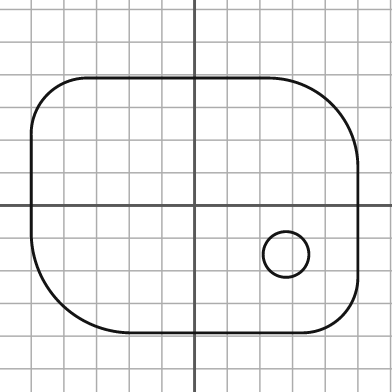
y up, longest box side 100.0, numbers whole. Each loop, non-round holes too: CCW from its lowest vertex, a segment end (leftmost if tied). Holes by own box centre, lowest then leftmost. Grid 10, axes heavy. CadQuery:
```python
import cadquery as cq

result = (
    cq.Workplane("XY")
    .moveTo(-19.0, -39.0)
    .lineTo(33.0, -39.0)
    .threePointArc((45.0, -34.0), (50.0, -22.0))
    .lineTo(50.0, 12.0)
    .threePointArc((42.0, 31.0), (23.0, 39.0))
    .lineTo(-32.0, 39.0)
    .threePointArc((-45.0, 34.0), (-50.0, 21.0))
    .lineTo(-50.0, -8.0)
    .threePointArc((-41.0, -30.0), (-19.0, -39.0))
    .close()
    .moveTo(28.0, -15.0)
    .circle(7.0)
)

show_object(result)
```